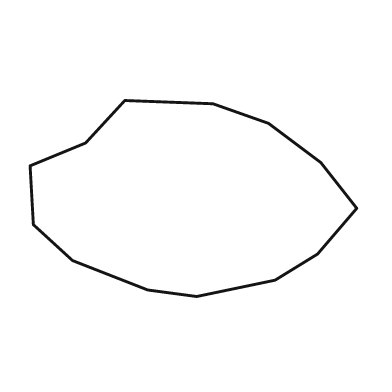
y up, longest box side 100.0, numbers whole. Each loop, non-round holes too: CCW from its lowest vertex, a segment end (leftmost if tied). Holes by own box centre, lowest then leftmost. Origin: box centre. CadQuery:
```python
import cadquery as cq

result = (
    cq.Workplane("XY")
    .moveTo(1.0, -30.0)
    .lineTo(25.0, -25.0)
    .lineTo(38.0, -17.0)
    .lineTo(50.0, -3.0)
    .lineTo(39.0, 11.0)
    .lineTo(23.0, 23.0)
    .lineTo(6.0, 29.0)
    .lineTo(-21.0, 30.0)
    .lineTo(-33.0, 17.0)
    .lineTo(-50.0, 10.0)
    .lineTo(-49.0, -8.0)
    .lineTo(-37.0, -19.0)
    .lineTo(-14.0, -28.0)
    .close()
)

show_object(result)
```